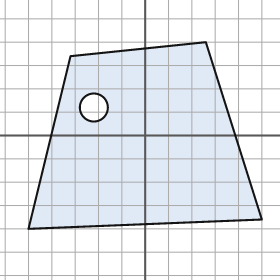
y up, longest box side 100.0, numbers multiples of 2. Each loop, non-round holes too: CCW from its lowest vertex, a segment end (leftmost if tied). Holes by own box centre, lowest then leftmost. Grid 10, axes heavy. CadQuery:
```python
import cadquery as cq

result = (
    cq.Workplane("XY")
    .moveTo(-50.0, -40.0)
    .lineTo(50.0, -36.0)
    .lineTo(26.0, 40.0)
    .lineTo(-32.0, 34.0)
    .close()
    .moveTo(-22.0, 12.0)
    .circle(6.0)
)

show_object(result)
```